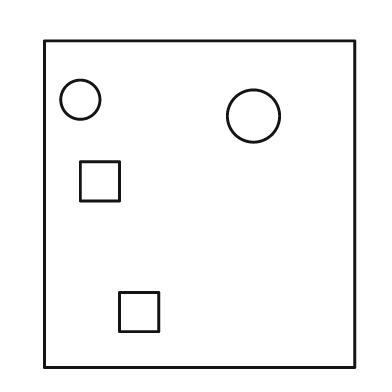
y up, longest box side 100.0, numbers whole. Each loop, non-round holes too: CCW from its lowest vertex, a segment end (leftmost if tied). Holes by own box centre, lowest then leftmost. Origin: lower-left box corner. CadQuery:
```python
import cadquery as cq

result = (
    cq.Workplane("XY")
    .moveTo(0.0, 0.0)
    .lineTo(95.0, 0.0)
    .lineTo(95.0, 100.0)
    .lineTo(0.0, 100.0)
    .close()
    .moveTo(23.0, 11.0)
    .lineTo(35.0, 11.0)
    .lineTo(35.0, 23.0)
    .lineTo(23.0, 23.0)
    .close()
    .moveTo(11.0, 51.0)
    .lineTo(23.0, 51.0)
    .lineTo(23.0, 63.0)
    .lineTo(11.0, 63.0)
    .close()
    .moveTo(64.0, 77.0)
    .circle(8.0)
    .moveTo(11.0, 82.0)
    .circle(6.0)
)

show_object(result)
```